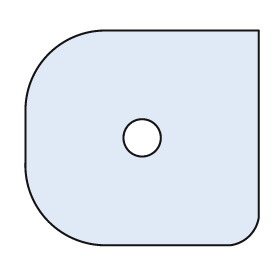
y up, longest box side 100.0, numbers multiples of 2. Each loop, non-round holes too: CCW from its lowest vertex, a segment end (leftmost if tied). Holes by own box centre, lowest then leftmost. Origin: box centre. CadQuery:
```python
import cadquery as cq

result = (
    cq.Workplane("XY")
    .moveTo(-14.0, -46.0)
    .lineTo(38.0, -46.0)
    .threePointArc((46.0, -42.0), (50.0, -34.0))
    .lineTo(50.0, 46.0)
    .lineTo(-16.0, 46.0)
    .threePointArc((-40.0, 36.0), (-50.0, 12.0))
    .lineTo(-50.0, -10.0)
    .threePointArc((-40.0, -36.0), (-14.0, -46.0))
    .close()
    .moveTo(0.0, 0.0)
    .circle(8.0)
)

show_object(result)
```